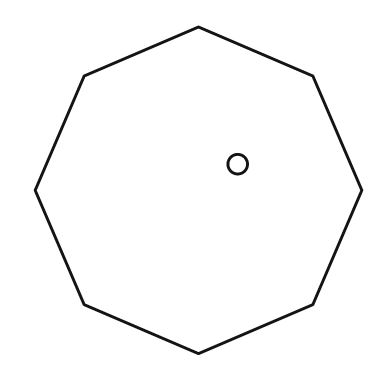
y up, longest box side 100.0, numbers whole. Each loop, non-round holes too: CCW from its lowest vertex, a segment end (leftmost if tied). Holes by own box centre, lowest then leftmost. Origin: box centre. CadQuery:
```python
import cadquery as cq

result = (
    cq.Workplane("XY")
    .moveTo(0.0, -50.0)
    .lineTo(35.0, -35.0)
    .lineTo(50.0, 0.0)
    .lineTo(35.0, 35.0)
    .lineTo(0.0, 50.0)
    .lineTo(-35.0, 35.0)
    .lineTo(-50.0, 0.0)
    .lineTo(-35.0, -35.0)
    .close()
    .moveTo(12.0, 8.0)
    .circle(3.0)
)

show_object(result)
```